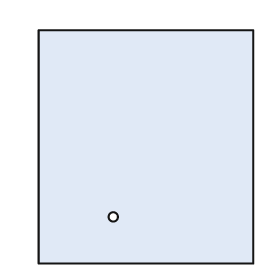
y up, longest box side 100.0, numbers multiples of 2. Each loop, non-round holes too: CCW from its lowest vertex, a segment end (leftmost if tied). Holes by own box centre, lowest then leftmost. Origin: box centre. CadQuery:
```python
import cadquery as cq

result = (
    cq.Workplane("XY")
    .moveTo(-46.0, -50.0)
    .lineTo(46.0, -50.0)
    .lineTo(46.0, 50.0)
    .lineTo(-46.0, 50.0)
    .close()
    .moveTo(-14.0, -30.0)
    .circle(2.0)
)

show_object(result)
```